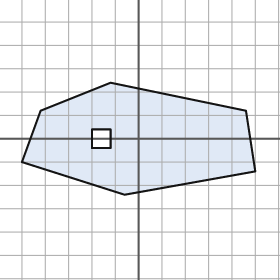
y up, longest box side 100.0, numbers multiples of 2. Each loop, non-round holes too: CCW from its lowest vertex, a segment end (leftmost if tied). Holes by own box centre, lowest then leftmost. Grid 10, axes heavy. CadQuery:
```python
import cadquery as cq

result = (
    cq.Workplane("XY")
    .moveTo(-6.0, -24.0)
    .lineTo(50.0, -14.0)
    .lineTo(46.0, 12.0)
    .lineTo(-12.0, 24.0)
    .lineTo(-42.0, 12.0)
    .lineTo(-50.0, -10.0)
    .close()
    .moveTo(-20.0, -4.0)
    .lineTo(-12.0, -4.0)
    .lineTo(-12.0, 4.0)
    .lineTo(-20.0, 4.0)
    .close()
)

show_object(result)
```